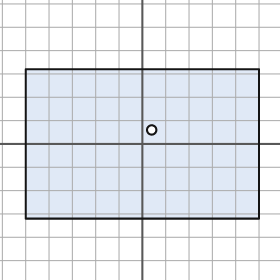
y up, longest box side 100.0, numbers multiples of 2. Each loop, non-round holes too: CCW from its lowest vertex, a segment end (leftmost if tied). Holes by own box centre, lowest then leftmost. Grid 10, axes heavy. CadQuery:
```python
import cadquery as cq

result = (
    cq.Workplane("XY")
    .moveTo(-50.0, -32.0)
    .lineTo(50.0, -32.0)
    .lineTo(50.0, 32.0)
    .lineTo(-50.0, 32.0)
    .close()
    .moveTo(4.0, 6.0)
    .circle(2.0)
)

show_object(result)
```